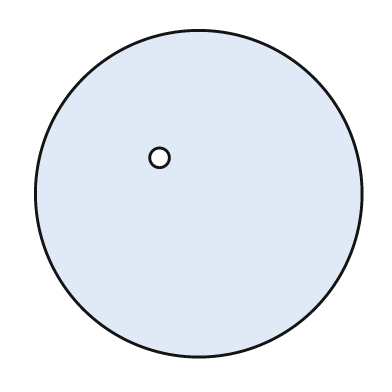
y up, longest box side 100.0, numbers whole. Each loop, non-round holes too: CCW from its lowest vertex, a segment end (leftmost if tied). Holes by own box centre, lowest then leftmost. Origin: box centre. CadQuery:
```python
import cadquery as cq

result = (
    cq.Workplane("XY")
    .moveTo(0.0, 0.0)
    .circle(50.0)
    .moveTo(-12.0, 11.0)
    .circle(3.0)
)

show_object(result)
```